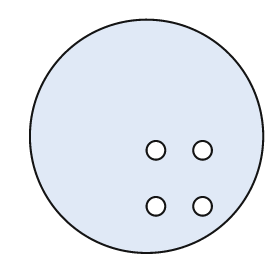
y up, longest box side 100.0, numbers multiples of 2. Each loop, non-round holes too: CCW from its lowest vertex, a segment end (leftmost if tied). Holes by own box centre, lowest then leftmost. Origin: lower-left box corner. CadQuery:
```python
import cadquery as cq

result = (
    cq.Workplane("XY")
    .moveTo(50.0, 50.0)
    .circle(50.0)
    .moveTo(54.0, 20.0)
    .circle(4.0)
    .moveTo(74.0, 20.0)
    .circle(4.0)
    .moveTo(54.0, 44.0)
    .circle(4.0)
    .moveTo(74.0, 44.0)
    .circle(4.0)
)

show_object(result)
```